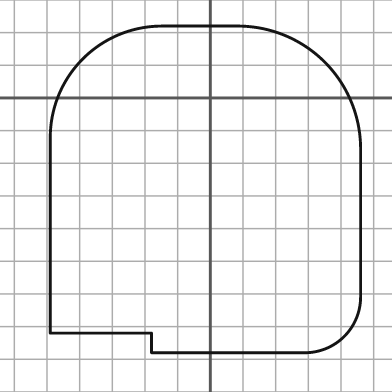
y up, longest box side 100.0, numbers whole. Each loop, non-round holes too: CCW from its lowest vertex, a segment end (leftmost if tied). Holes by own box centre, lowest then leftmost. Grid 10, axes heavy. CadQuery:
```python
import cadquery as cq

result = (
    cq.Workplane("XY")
    .moveTo(-18.0, -78.0)
    .lineTo(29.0, -78.0)
    .threePointArc((41.0, -73.0), (46.0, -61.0))
    .lineTo(46.0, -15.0)
    .threePointArc((35.0, 11.0), (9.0, 22.0))
    .lineTo(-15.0, 22.0)
    .threePointArc((-39.0, 12.0), (-49.0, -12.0))
    .lineTo(-49.0, -72.0)
    .lineTo(-18.0, -72.0)
    .close()
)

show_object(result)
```